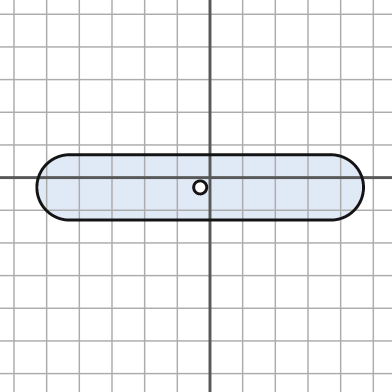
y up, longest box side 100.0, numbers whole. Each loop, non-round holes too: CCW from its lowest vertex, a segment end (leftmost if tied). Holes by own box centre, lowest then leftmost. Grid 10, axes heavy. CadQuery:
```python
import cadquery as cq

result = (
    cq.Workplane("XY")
    .moveTo(-43.0, -13.0)
    .lineTo(37.0, -13.0)
    .threePointArc((47.0, -3.0), (37.0, 7.0))
    .lineTo(-43.0, 7.0)
    .threePointArc((-53.0, -3.0), (-43.0, -13.0))
    .close()
    .moveTo(-3.0, -3.0)
    .circle(2.0)
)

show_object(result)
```